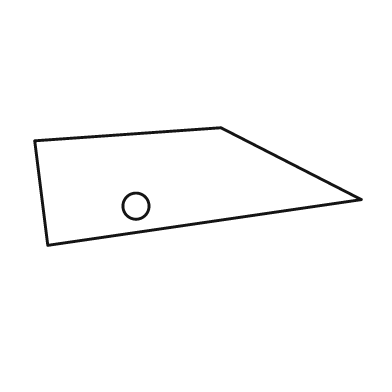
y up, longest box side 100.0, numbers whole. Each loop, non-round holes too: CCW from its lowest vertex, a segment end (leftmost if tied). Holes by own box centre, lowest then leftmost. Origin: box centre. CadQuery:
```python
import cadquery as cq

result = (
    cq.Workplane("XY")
    .moveTo(-46.0, -18.0)
    .lineTo(50.0, -4.0)
    .lineTo(7.0, 18.0)
    .lineTo(-50.0, 14.0)
    .close()
    .moveTo(-19.0, -6.0)
    .circle(4.0)
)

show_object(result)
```